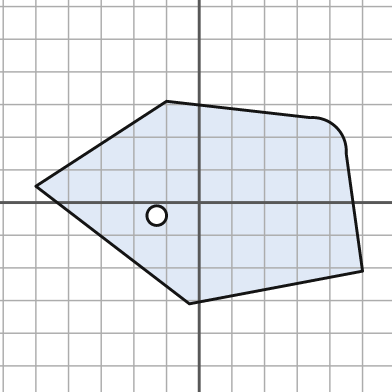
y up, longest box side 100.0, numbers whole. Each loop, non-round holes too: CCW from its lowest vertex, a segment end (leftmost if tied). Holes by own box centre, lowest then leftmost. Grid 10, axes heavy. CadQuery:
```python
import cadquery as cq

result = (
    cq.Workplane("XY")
    .moveTo(-3.0, -31.0)
    .lineTo(50.0, -21.0)
    .lineTo(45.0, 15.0)
    .threePointArc((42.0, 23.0), (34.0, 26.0))
    .lineTo(-10.0, 31.0)
    .lineTo(-50.0, 5.0)
    .close()
    .moveTo(-13.0, -4.0)
    .circle(3.0)
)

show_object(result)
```